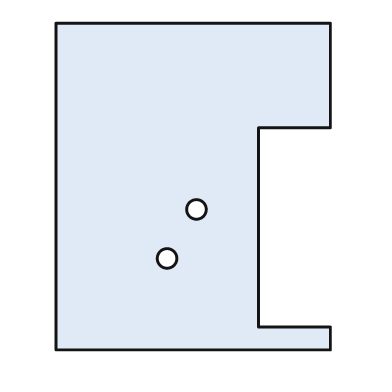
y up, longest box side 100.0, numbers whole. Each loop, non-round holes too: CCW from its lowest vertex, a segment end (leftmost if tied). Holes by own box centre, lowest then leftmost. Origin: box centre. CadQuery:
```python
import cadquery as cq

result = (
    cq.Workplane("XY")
    .moveTo(-42.0, -50.0)
    .lineTo(42.0, -50.0)
    .lineTo(42.0, -43.0)
    .lineTo(20.0, -43.0)
    .lineTo(20.0, 18.0)
    .lineTo(42.0, 18.0)
    .lineTo(42.0, 50.0)
    .lineTo(-42.0, 50.0)
    .close()
    .moveTo(-8.0, -22.0)
    .circle(3.0)
    .moveTo(1.0, -7.0)
    .circle(3.0)
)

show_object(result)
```